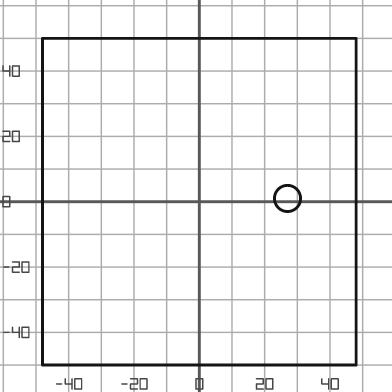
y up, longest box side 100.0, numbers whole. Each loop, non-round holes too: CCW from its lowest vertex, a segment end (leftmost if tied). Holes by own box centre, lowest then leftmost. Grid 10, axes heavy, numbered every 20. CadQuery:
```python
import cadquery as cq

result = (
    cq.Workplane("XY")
    .moveTo(-48.0, -50.0)
    .lineTo(48.0, -50.0)
    .lineTo(48.0, 50.0)
    .lineTo(-48.0, 50.0)
    .close()
    .moveTo(27.0, 1.0)
    .circle(4.0)
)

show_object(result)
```